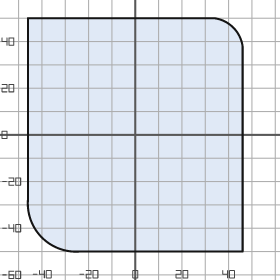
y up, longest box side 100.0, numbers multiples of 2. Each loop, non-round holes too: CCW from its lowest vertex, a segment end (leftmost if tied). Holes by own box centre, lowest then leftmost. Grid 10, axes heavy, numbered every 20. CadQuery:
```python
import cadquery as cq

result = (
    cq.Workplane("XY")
    .moveTo(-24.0, -50.0)
    .lineTo(46.0, -50.0)
    .lineTo(46.0, 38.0)
    .threePointArc((42.0, 46.0), (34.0, 50.0))
    .lineTo(-46.0, 50.0)
    .lineTo(-46.0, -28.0)
    .threePointArc((-40.0, -44.0), (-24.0, -50.0))
    .close()
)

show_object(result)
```